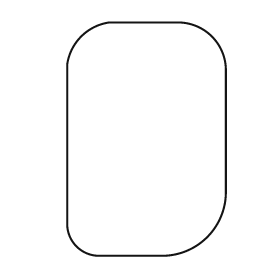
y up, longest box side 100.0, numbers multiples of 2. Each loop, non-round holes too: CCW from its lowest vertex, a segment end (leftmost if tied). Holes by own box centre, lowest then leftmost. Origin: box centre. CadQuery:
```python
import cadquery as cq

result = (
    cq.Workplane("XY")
    .moveTo(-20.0, -50.0)
    .lineTo(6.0, -50.0)
    .threePointArc((26.0, -42.0), (34.0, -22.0))
    .lineTo(34.0, 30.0)
    .threePointArc((28.0, 44.0), (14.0, 50.0))
    .lineTo(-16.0, 50.0)
    .threePointArc((-28.0, 44.0), (-34.0, 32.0))
    .lineTo(-34.0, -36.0)
    .threePointArc((-30.0, -46.0), (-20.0, -50.0))
    .close()
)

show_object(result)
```